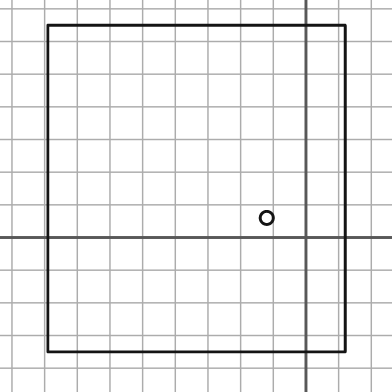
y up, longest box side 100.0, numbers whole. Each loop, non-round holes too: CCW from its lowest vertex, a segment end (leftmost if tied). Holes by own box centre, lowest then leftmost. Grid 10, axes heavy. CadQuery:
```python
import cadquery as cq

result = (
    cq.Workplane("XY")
    .moveTo(-79.0, -35.0)
    .lineTo(12.0, -35.0)
    .lineTo(12.0, 65.0)
    .lineTo(-79.0, 65.0)
    .close()
    .moveTo(-12.0, 6.0)
    .circle(2.0)
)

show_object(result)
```